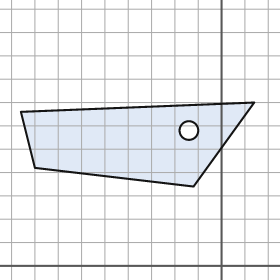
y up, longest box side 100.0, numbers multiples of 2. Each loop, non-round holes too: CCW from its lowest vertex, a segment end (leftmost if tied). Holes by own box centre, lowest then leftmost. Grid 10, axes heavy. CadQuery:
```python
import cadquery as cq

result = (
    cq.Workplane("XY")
    .moveTo(-12.0, 34.0)
    .lineTo(14.0, 70.0)
    .lineTo(-86.0, 66.0)
    .lineTo(-80.0, 42.0)
    .close()
    .moveTo(-14.0, 58.0)
    .circle(4.0)
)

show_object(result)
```